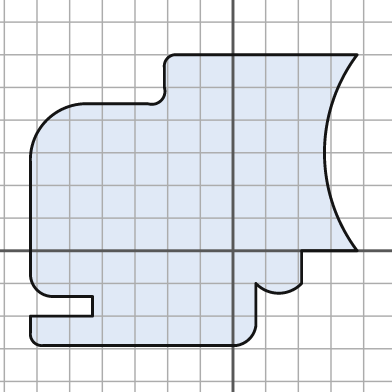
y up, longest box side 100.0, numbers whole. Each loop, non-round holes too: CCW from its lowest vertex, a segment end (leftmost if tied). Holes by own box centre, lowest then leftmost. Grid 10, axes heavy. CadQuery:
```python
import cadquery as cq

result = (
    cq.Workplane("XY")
    .moveTo(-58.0, -29.0)
    .lineTo(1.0, -29.0)
    .threePointArc((5.0, -27.0), (7.0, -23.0))
    .lineTo(7.0, -10.0)
    .threePointArc((14.0, -13.0), (21.0, -10.0))
    .lineTo(21.0, 0.0)
    .lineTo(38.0, 0.0)
    .threePointArc((28.0, 30.0), (38.0, 60.0))
    .lineTo(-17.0, 60.0)
    .threePointArc((-20.0, 59.0), (-21.0, 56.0))
    .lineTo(-21.0, 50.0)
    .threePointArc((-22.0, 46.0), (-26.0, 45.0))
    .lineTo(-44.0, 45.0)
    .threePointArc((-57.0, 40.0), (-62.0, 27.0))
    .lineTo(-62.0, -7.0)
    .threePointArc((-60.0, -12.0), (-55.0, -14.0))
    .lineTo(-43.0, -14.0)
    .lineTo(-43.0, -20.0)
    .lineTo(-62.0, -20.0)
    .lineTo(-62.0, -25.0)
    .threePointArc((-61.0, -28.0), (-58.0, -29.0))
    .close()
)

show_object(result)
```